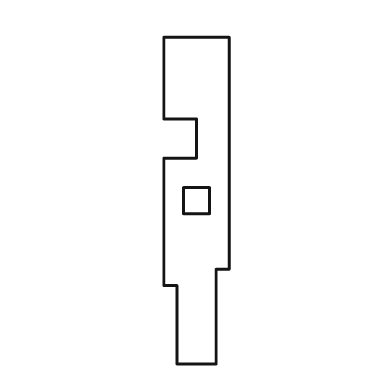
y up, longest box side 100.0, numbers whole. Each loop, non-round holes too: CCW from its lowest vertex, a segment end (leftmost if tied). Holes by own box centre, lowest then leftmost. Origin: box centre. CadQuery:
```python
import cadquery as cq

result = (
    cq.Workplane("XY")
    .moveTo(-6.0, -50.0)
    .lineTo(6.0, -50.0)
    .lineTo(6.0, -21.0)
    .lineTo(10.0, -21.0)
    .lineTo(10.0, 50.0)
    .lineTo(-10.0, 50.0)
    .lineTo(-10.0, 25.0)
    .lineTo(0.0, 25.0)
    .lineTo(0.0, 13.0)
    .lineTo(-10.0, 13.0)
    .lineTo(-10.0, -26.0)
    .lineTo(-6.0, -26.0)
    .close()
    .moveTo(-4.0, -4.0)
    .lineTo(4.0, -4.0)
    .lineTo(4.0, 4.0)
    .lineTo(-4.0, 4.0)
    .close()
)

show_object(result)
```